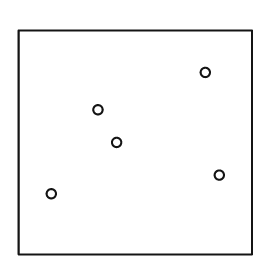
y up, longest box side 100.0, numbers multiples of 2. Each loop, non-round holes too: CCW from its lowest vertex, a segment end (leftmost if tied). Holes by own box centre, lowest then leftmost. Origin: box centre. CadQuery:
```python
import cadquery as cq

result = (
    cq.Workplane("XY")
    .moveTo(-50.0, -48.0)
    .lineTo(50.0, -48.0)
    .lineTo(50.0, 48.0)
    .lineTo(-50.0, 48.0)
    .close()
    .moveTo(-36.0, -22.0)
    .circle(2.0)
    .moveTo(36.0, -14.0)
    .circle(2.0)
    .moveTo(-8.0, 0.0)
    .circle(2.0)
    .moveTo(-16.0, 14.0)
    .circle(2.0)
    .moveTo(30.0, 30.0)
    .circle(2.0)
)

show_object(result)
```